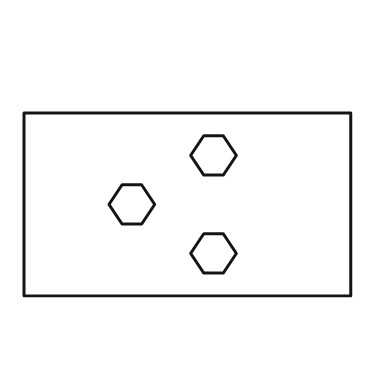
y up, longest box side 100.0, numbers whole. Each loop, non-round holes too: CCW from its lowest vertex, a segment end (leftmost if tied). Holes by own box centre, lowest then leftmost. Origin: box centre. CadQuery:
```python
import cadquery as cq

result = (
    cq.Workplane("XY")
    .moveTo(-50.0, -28.0)
    .lineTo(50.0, -28.0)
    .lineTo(50.0, 28.0)
    .lineTo(-50.0, 28.0)
    .close()
    .moveTo(5.0, -21.0)
    .lineTo(11.0, -21.0)
    .lineTo(15.0, -15.0)
    .lineTo(11.0, -9.0)
    .lineTo(5.0, -9.0)
    .lineTo(1.0, -15.0)
    .close()
    .moveTo(-20.0, -6.0)
    .lineTo(-14.0, -6.0)
    .lineTo(-10.0, 0.0)
    .lineTo(-14.0, 6.0)
    .lineTo(-20.0, 6.0)
    .lineTo(-24.0, 0.0)
    .close()
    .moveTo(5.0, 9.0)
    .lineTo(11.0, 9.0)
    .lineTo(15.0, 15.0)
    .lineTo(11.0, 21.0)
    .lineTo(5.0, 21.0)
    .lineTo(1.0, 15.0)
    .close()
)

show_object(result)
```